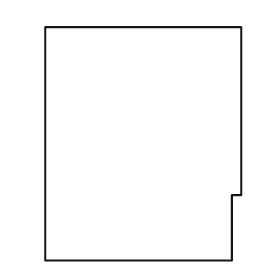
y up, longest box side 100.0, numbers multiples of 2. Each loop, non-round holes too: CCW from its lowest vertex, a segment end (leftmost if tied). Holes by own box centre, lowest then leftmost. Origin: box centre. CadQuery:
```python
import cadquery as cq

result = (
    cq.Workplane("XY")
    .moveTo(-42.0, -50.0)
    .lineTo(38.0, -50.0)
    .lineTo(38.0, -22.0)
    .lineTo(42.0, -22.0)
    .lineTo(42.0, 50.0)
    .lineTo(-42.0, 50.0)
    .close()
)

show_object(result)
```